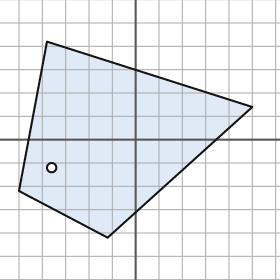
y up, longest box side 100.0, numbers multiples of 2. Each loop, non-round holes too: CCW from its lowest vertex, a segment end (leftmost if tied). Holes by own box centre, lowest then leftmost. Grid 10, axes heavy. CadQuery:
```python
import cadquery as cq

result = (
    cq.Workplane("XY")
    .moveTo(-12.0, -42.0)
    .lineTo(50.0, 14.0)
    .lineTo(-38.0, 42.0)
    .lineTo(-50.0, -22.0)
    .close()
    .moveTo(-36.0, -12.0)
    .circle(2.0)
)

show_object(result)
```